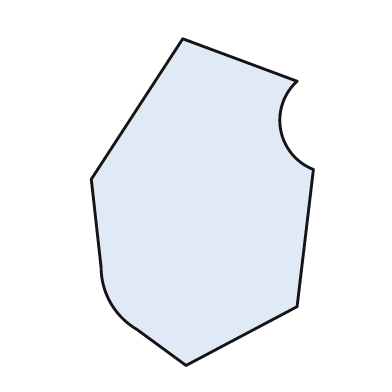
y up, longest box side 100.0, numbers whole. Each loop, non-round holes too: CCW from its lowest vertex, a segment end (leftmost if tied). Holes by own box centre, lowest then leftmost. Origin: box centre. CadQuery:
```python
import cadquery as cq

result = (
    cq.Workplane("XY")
    .moveTo(-5.0, -50.0)
    .lineTo(29.0, -32.0)
    .lineTo(34.0, 10.0)
    .threePointArc((24.0, 22.0), (29.0, 37.0))
    .lineTo(-6.0, 50.0)
    .lineTo(-34.0, 7.0)
    .lineTo(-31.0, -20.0)
    .threePointArc((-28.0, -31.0), (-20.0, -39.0))
    .close()
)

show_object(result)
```